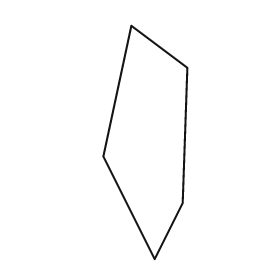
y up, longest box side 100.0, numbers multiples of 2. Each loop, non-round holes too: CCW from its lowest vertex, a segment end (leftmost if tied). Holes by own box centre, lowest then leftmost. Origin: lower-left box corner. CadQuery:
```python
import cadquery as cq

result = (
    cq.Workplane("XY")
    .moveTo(22.0, 0.0)
    .lineTo(34.0, 24.0)
    .lineTo(36.0, 82.0)
    .lineTo(12.0, 100.0)
    .lineTo(0.0, 44.0)
    .close()
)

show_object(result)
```